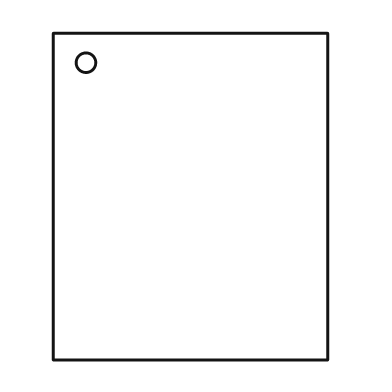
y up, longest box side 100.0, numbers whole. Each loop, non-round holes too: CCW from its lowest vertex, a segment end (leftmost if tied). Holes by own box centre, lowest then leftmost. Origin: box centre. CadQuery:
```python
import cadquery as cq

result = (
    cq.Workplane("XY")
    .moveTo(-42.0, -50.0)
    .lineTo(42.0, -50.0)
    .lineTo(42.0, 50.0)
    .lineTo(-42.0, 50.0)
    .close()
    .moveTo(-32.0, 41.0)
    .circle(3.0)
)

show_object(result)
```